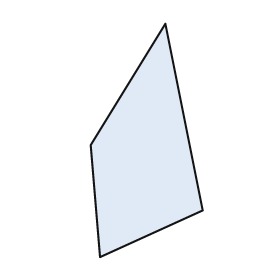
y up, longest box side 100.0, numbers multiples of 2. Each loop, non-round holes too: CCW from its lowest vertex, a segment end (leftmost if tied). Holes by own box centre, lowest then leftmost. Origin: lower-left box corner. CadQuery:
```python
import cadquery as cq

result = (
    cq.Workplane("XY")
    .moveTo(4.0, 0.0)
    .lineTo(48.0, 20.0)
    .lineTo(32.0, 100.0)
    .lineTo(0.0, 48.0)
    .close()
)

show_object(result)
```